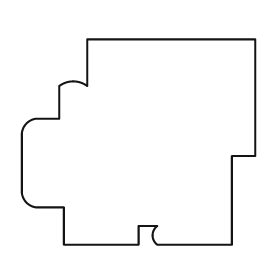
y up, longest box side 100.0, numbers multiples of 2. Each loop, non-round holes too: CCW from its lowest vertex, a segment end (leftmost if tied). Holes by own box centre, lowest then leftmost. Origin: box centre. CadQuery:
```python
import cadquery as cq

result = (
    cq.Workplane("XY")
    .moveTo(-32.0, -44.0)
    .lineTo(0.0, -44.0)
    .lineTo(0.0, -36.0)
    .lineTo(8.0, -36.0)
    .threePointArc((6.0, -40.0), (8.0, -44.0))
    .lineTo(40.0, -44.0)
    .lineTo(40.0, -6.0)
    .lineTo(50.0, -6.0)
    .lineTo(50.0, 44.0)
    .lineTo(-22.0, 44.0)
    .lineTo(-22.0, 24.0)
    .threePointArc((-28.0, 26.0), (-34.0, 24.0))
    .lineTo(-34.0, 10.0)
    .lineTo(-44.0, 10.0)
    .threePointArc((-48.0, 8.0), (-50.0, 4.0))
    .lineTo(-50.0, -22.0)
    .threePointArc((-48.0, -26.0), (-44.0, -28.0))
    .lineTo(-32.0, -28.0)
    .close()
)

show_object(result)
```